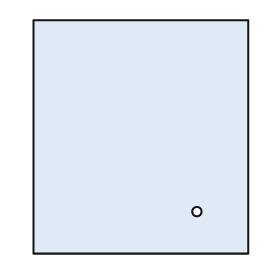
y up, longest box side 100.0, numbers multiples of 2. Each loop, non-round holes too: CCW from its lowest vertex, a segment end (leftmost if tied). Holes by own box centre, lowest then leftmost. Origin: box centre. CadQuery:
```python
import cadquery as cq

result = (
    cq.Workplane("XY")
    .moveTo(-46.0, -50.0)
    .lineTo(46.0, -50.0)
    .lineTo(46.0, 50.0)
    .lineTo(-46.0, 50.0)
    .close()
    .moveTo(24.0, -32.0)
    .circle(2.0)
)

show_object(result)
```